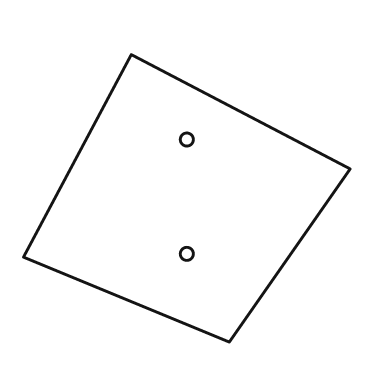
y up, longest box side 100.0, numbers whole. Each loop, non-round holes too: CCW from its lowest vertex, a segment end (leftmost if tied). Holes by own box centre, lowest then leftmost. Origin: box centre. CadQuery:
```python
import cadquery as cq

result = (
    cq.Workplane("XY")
    .moveTo(13.0, -44.0)
    .lineTo(50.0, 9.0)
    .lineTo(-17.0, 44.0)
    .lineTo(-50.0, -18.0)
    .close()
    .moveTo(0.0, -17.0)
    .circle(2.0)
    .moveTo(0.0, 18.0)
    .circle(2.0)
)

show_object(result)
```